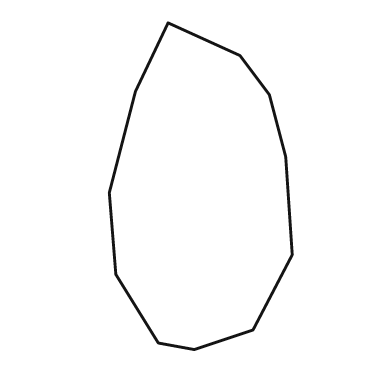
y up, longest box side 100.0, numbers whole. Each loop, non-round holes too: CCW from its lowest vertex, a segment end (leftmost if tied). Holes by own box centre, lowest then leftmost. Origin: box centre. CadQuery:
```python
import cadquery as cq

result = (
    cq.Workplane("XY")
    .moveTo(-2.0, -50.0)
    .lineTo(16.0, -44.0)
    .lineTo(28.0, -21.0)
    .lineTo(26.0, 9.0)
    .lineTo(21.0, 28.0)
    .lineTo(12.0, 40.0)
    .lineTo(-10.0, 50.0)
    .lineTo(-20.0, 29.0)
    .lineTo(-28.0, -2.0)
    .lineTo(-26.0, -27.0)
    .lineTo(-13.0, -48.0)
    .close()
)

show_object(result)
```